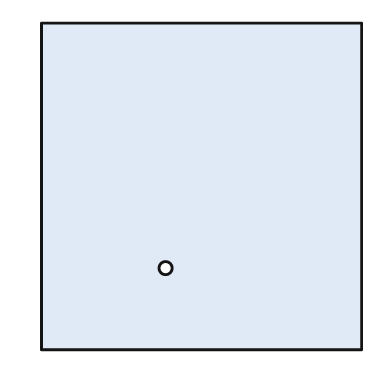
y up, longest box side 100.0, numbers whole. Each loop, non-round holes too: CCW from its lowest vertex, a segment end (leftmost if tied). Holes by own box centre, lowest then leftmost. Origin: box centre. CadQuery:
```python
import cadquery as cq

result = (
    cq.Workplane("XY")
    .moveTo(-49.0, -50.0)
    .lineTo(49.0, -50.0)
    .lineTo(49.0, 50.0)
    .lineTo(-49.0, 50.0)
    .close()
    .moveTo(-11.0, -25.0)
    .circle(2.0)
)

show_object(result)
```